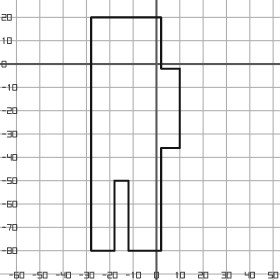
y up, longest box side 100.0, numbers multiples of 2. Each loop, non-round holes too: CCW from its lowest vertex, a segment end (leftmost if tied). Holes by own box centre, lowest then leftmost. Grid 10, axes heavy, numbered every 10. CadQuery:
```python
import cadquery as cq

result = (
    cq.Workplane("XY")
    .moveTo(-28.0, -80.0)
    .lineTo(-18.0, -80.0)
    .lineTo(-18.0, -50.0)
    .lineTo(-12.0, -50.0)
    .lineTo(-12.0, -80.0)
    .lineTo(2.0, -80.0)
    .lineTo(2.0, -36.0)
    .lineTo(10.0, -36.0)
    .lineTo(10.0, -2.0)
    .lineTo(2.0, -2.0)
    .lineTo(2.0, 20.0)
    .lineTo(-28.0, 20.0)
    .close()
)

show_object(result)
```